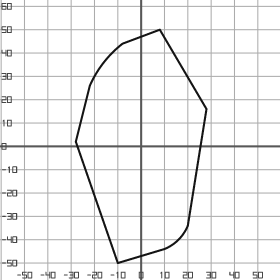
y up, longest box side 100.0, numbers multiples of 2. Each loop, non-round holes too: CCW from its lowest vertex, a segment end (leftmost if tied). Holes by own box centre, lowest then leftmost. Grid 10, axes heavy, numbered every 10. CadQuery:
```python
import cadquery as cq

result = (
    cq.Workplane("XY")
    .moveTo(-10.0, -50.0)
    .lineTo(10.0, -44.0)
    .threePointArc((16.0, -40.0), (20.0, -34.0))
    .lineTo(28.0, 16.0)
    .lineTo(8.0, 50.0)
    .lineTo(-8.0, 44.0)
    .threePointArc((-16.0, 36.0), (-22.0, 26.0))
    .lineTo(-28.0, 2.0)
    .close()
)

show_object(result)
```